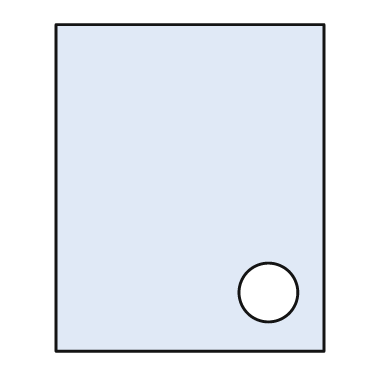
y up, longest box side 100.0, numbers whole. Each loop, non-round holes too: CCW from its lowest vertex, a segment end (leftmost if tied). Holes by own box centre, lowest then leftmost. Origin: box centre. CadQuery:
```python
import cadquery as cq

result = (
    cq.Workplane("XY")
    .moveTo(-41.0, -50.0)
    .lineTo(41.0, -50.0)
    .lineTo(41.0, 50.0)
    .lineTo(-41.0, 50.0)
    .close()
    .moveTo(24.0, -32.0)
    .circle(9.0)
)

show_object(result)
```